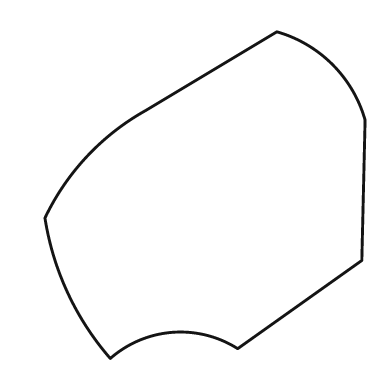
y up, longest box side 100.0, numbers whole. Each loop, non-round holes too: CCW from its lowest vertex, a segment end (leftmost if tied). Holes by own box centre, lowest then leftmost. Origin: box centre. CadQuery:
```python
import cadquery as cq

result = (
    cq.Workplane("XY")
    .moveTo(-29.0, -50.0)
    .threePointArc((-10.0, -42.0), (10.0, -47.0))
    .lineTo(48.0, -20.0)
    .lineTo(49.0, 23.0)
    .threePointArc((39.0, 40.0), (22.0, 50.0))
    .lineTo(-18.0, 26.0)
    .threePointArc((-36.0, 12.0), (-49.0, -7.0))
    .threePointArc((-42.0, -30.0), (-29.0, -50.0))
    .close()
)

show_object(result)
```